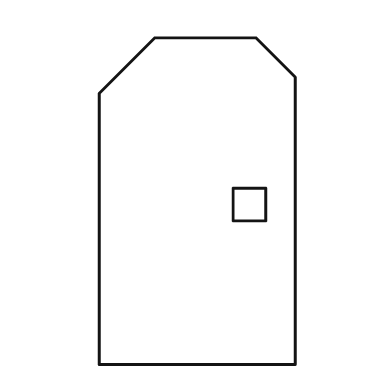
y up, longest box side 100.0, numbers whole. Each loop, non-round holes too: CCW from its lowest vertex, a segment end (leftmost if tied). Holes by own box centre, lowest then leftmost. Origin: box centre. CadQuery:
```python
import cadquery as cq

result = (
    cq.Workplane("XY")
    .moveTo(-30.0, -50.0)
    .lineTo(30.0, -50.0)
    .lineTo(30.0, 38.0)
    .lineTo(18.0, 50.0)
    .lineTo(-13.0, 50.0)
    .lineTo(-30.0, 33.0)
    .close()
    .moveTo(11.0, -6.0)
    .lineTo(21.0, -6.0)
    .lineTo(21.0, 4.0)
    .lineTo(11.0, 4.0)
    .close()
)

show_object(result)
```